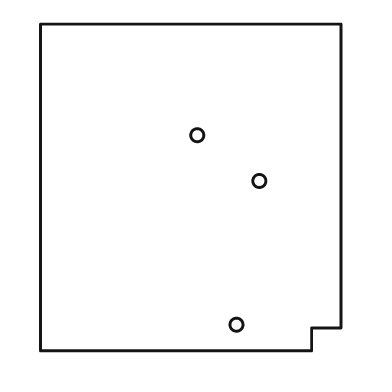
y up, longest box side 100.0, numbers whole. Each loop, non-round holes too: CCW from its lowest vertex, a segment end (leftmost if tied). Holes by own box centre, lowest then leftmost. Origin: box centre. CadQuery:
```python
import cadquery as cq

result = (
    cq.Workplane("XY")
    .moveTo(-46.0, -50.0)
    .lineTo(37.0, -50.0)
    .lineTo(37.0, -43.0)
    .lineTo(46.0, -43.0)
    .lineTo(46.0, 50.0)
    .lineTo(-46.0, 50.0)
    .close()
    .moveTo(14.0, -42.0)
    .circle(2.0)
    .moveTo(21.0, 2.0)
    .circle(2.0)
    .moveTo(2.0, 16.0)
    .circle(2.0)
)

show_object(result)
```